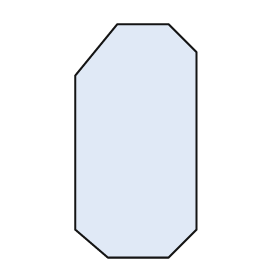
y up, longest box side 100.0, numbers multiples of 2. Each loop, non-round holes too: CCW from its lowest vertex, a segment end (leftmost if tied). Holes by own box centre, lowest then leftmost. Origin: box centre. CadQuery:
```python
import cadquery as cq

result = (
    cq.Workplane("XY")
    .moveTo(-12.0, -50.0)
    .lineTo(14.0, -50.0)
    .lineTo(26.0, -38.0)
    .lineTo(26.0, 38.0)
    .lineTo(14.0, 50.0)
    .lineTo(-8.0, 50.0)
    .lineTo(-26.0, 28.0)
    .lineTo(-26.0, -38.0)
    .close()
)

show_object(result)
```